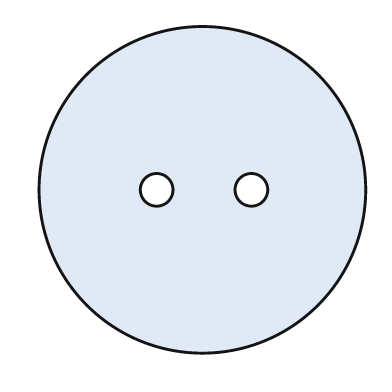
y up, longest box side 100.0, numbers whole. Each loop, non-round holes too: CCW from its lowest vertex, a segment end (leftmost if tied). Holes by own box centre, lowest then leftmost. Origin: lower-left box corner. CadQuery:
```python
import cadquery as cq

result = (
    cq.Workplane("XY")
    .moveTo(50.0, 50.0)
    .circle(50.0)
    .moveTo(36.0, 50.0)
    .circle(5.0)
    .moveTo(65.0, 50.0)
    .circle(5.0)
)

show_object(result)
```